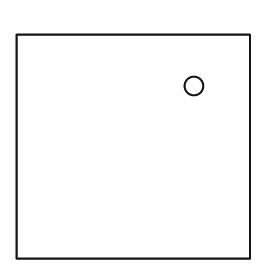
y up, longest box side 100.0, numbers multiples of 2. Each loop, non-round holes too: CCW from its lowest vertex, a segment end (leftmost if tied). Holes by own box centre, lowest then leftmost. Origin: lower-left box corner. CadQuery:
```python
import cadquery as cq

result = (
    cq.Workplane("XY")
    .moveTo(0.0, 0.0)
    .lineTo(100.0, 0.0)
    .lineTo(100.0, 96.0)
    .lineTo(0.0, 96.0)
    .close()
    .moveTo(76.0, 74.0)
    .circle(4.0)
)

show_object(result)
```